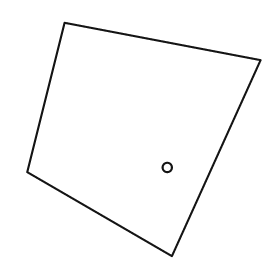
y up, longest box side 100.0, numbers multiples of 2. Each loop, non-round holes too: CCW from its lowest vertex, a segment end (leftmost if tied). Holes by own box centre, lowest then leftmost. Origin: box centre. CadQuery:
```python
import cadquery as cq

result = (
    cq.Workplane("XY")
    .moveTo(12.0, -50.0)
    .lineTo(50.0, 34.0)
    .lineTo(-34.0, 50.0)
    .lineTo(-50.0, -14.0)
    .close()
    .moveTo(10.0, -12.0)
    .circle(2.0)
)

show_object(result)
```